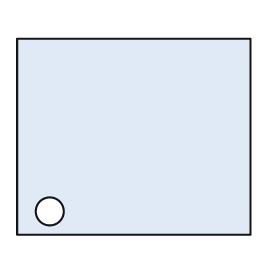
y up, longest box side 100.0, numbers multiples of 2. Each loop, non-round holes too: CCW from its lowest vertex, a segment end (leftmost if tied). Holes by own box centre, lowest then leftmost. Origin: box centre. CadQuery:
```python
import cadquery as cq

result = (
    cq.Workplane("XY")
    .moveTo(-50.0, -42.0)
    .lineTo(50.0, -42.0)
    .lineTo(50.0, 42.0)
    .lineTo(-50.0, 42.0)
    .close()
    .moveTo(-36.0, -32.0)
    .circle(6.0)
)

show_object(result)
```